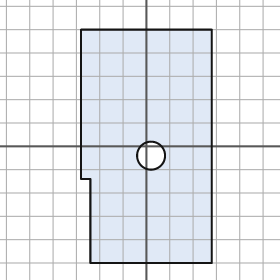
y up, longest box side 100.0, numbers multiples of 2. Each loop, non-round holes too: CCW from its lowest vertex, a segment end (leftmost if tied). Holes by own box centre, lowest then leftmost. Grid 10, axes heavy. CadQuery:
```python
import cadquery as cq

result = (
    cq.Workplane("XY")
    .moveTo(-24.0, -50.0)
    .lineTo(28.0, -50.0)
    .lineTo(28.0, 50.0)
    .lineTo(-28.0, 50.0)
    .lineTo(-28.0, -14.0)
    .lineTo(-24.0, -14.0)
    .close()
    .moveTo(2.0, -4.0)
    .circle(6.0)
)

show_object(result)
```